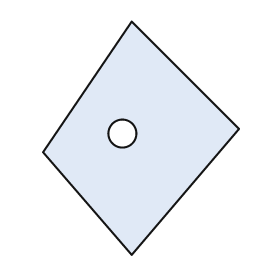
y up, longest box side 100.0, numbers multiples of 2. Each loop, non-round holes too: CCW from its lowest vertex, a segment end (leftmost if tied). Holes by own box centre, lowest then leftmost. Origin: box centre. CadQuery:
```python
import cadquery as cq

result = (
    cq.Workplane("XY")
    .moveTo(-4.0, -50.0)
    .lineTo(42.0, 4.0)
    .lineTo(-4.0, 50.0)
    .lineTo(-42.0, -6.0)
    .close()
    .moveTo(-8.0, 2.0)
    .circle(6.0)
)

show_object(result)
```